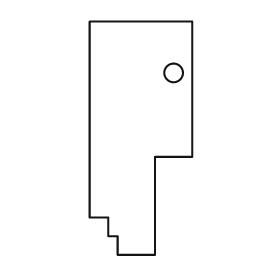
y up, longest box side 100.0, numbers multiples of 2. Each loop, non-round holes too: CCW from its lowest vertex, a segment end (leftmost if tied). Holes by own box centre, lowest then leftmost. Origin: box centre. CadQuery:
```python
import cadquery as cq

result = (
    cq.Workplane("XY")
    .moveTo(-10.0, -50.0)
    .lineTo(6.0, -50.0)
    .lineTo(6.0, -8.0)
    .lineTo(22.0, -8.0)
    .lineTo(22.0, 50.0)
    .lineTo(-22.0, 50.0)
    .lineTo(-22.0, -34.0)
    .lineTo(-14.0, -34.0)
    .lineTo(-14.0, -42.0)
    .lineTo(-10.0, -42.0)
    .close()
    .moveTo(14.0, 28.0)
    .circle(4.0)
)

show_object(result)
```